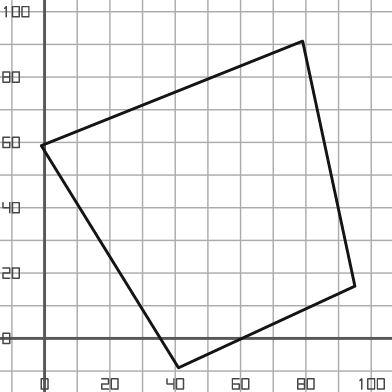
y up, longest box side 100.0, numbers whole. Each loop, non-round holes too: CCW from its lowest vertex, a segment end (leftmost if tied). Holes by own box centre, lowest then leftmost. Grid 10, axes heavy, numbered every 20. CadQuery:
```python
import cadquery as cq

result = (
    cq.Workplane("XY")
    .moveTo(41.0, -9.0)
    .lineTo(95.0, 16.0)
    .lineTo(79.0, 91.0)
    .lineTo(-1.0, 59.0)
    .close()
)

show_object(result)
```